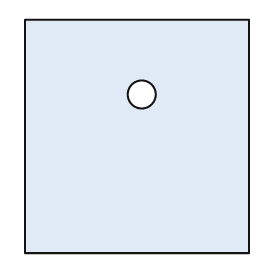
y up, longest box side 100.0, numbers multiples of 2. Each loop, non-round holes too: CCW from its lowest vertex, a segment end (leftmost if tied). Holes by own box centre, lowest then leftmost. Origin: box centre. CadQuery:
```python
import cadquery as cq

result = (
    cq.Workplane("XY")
    .moveTo(-48.0, -50.0)
    .lineTo(48.0, -50.0)
    .lineTo(48.0, 50.0)
    .lineTo(-48.0, 50.0)
    .close()
    .moveTo(2.0, 18.0)
    .circle(6.0)
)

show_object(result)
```